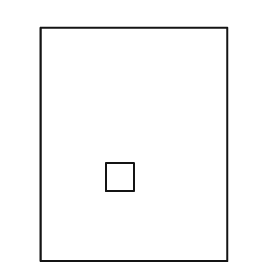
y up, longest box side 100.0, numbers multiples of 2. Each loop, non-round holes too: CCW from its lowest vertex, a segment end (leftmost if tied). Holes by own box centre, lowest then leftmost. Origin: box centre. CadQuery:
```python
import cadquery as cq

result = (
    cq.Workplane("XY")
    .moveTo(-40.0, -50.0)
    .lineTo(40.0, -50.0)
    .lineTo(40.0, 50.0)
    .lineTo(-40.0, 50.0)
    .close()
    .moveTo(-12.0, -20.0)
    .lineTo(0.0, -20.0)
    .lineTo(0.0, -8.0)
    .lineTo(-12.0, -8.0)
    .close()
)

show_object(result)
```